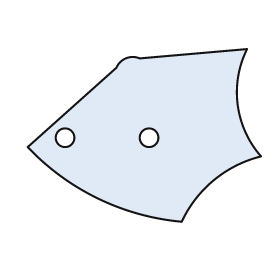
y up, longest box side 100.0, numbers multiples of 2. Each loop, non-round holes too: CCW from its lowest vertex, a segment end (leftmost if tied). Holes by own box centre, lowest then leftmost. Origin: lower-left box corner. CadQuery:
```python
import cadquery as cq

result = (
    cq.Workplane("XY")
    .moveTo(66.0, 0.0)
    .threePointArc((80.0, 18.0), (100.0, 28.0))
    .threePointArc((90.0, 50.0), (94.0, 74.0))
    .lineTo(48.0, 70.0)
    .threePointArc((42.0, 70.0), (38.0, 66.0))
    .lineTo(0.0, 32.0)
    .threePointArc((30.0, 10.0), (66.0, 0.0))
    .close()
    .moveTo(16.0, 36.0)
    .circle(4.0)
    .moveTo(52.0, 36.0)
    .circle(4.0)
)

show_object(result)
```